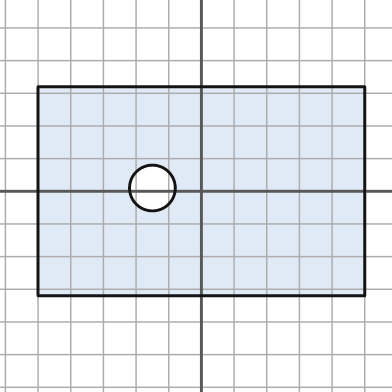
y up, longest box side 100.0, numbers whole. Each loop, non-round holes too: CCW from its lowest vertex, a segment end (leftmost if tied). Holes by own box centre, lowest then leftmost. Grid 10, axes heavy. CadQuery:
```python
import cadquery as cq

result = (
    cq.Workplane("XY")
    .moveTo(-50.0, -32.0)
    .lineTo(50.0, -32.0)
    .lineTo(50.0, 32.0)
    .lineTo(-50.0, 32.0)
    .close()
    .moveTo(-15.0, 1.0)
    .circle(7.0)
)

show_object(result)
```